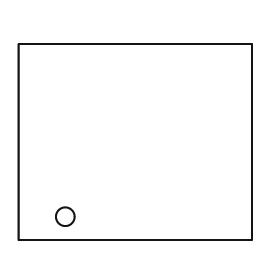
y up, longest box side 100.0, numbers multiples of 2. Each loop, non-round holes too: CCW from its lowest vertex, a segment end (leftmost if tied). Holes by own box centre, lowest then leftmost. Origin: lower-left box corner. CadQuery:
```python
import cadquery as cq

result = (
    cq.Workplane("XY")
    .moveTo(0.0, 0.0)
    .lineTo(100.0, 0.0)
    .lineTo(100.0, 84.0)
    .lineTo(0.0, 84.0)
    .close()
    .moveTo(20.0, 10.0)
    .circle(4.0)
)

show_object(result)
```